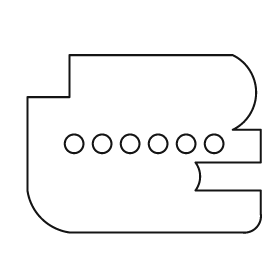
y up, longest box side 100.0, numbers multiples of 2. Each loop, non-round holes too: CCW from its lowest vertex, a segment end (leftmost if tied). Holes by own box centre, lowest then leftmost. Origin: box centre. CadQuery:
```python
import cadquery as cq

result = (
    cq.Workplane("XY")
    .moveTo(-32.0, -38.0)
    .lineTo(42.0, -38.0)
    .threePointArc((48.0, -36.0), (50.0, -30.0))
    .lineTo(50.0, -20.0)
    .lineTo(22.0, -20.0)
    .threePointArc((24.0, -14.0), (22.0, -8.0))
    .lineTo(50.0, -8.0)
    .lineTo(50.0, 6.0)
    .lineTo(38.0, 6.0)
    .threePointArc((48.0, 22.0), (38.0, 38.0))
    .lineTo(-32.0, 38.0)
    .lineTo(-32.0, 20.0)
    .lineTo(-50.0, 20.0)
    .lineTo(-50.0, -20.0)
    .threePointArc((-44.0, -32.0), (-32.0, -38.0))
    .close()
    .moveTo(-30.0, 0.0)
    .circle(4.0)
    .moveTo(-18.0, 0.0)
    .circle(4.0)
    .moveTo(-6.0, 0.0)
    .circle(4.0)
    .moveTo(6.0, 0.0)
    .circle(4.0)
    .moveTo(18.0, 0.0)
    .circle(4.0)
    .moveTo(30.0, 0.0)
    .circle(4.0)
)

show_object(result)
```